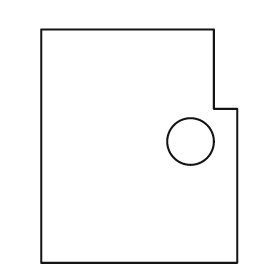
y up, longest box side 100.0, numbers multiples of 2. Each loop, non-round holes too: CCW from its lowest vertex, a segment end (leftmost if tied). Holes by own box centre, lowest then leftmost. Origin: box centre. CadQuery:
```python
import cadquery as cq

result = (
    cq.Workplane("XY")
    .moveTo(-42.0, -50.0)
    .lineTo(42.0, -50.0)
    .lineTo(42.0, 16.0)
    .lineTo(32.0, 16.0)
    .lineTo(32.0, 50.0)
    .lineTo(-42.0, 50.0)
    .close()
    .moveTo(22.0, 2.0)
    .circle(10.0)
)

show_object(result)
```